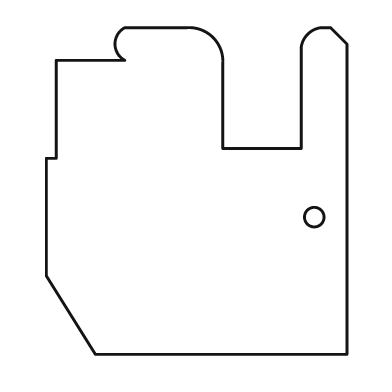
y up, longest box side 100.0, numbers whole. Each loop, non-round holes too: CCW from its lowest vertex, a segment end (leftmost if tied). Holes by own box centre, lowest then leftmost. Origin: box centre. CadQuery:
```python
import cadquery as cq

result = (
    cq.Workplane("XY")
    .moveTo(-31.0, -50.0)
    .lineTo(46.0, -50.0)
    .lineTo(46.0, 45.0)
    .lineTo(41.0, 50.0)
    .lineTo(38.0, 50.0)
    .threePointArc((34.0, 48.0), (32.0, 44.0))
    .lineTo(32.0, 13.0)
    .lineTo(8.0, 13.0)
    .lineTo(8.0, 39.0)
    .threePointArc((5.0, 47.0), (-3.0, 50.0))
    .lineTo(-22.0, 50.0)
    .threePointArc((-25.0, 45.0), (-22.0, 40.0))
    .lineTo(-43.0, 40.0)
    .lineTo(-43.0, 10.0)
    .lineTo(-46.0, 10.0)
    .lineTo(-46.0, -26.0)
    .close()
    .moveTo(36.0, -8.0)
    .circle(3.0)
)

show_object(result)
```